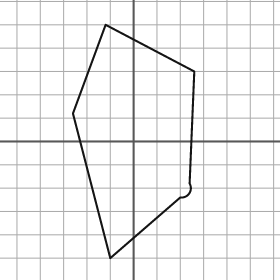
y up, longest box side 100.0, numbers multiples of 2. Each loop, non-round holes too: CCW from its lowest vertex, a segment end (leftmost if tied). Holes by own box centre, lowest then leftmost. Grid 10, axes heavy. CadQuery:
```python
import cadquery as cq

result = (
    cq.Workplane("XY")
    .moveTo(-10.0, -50.0)
    .lineTo(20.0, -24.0)
    .threePointArc((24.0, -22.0), (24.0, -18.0))
    .lineTo(26.0, 30.0)
    .lineTo(-12.0, 50.0)
    .lineTo(-26.0, 12.0)
    .close()
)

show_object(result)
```